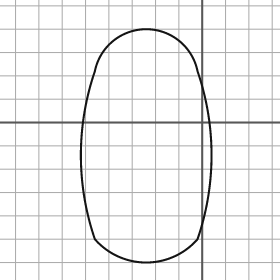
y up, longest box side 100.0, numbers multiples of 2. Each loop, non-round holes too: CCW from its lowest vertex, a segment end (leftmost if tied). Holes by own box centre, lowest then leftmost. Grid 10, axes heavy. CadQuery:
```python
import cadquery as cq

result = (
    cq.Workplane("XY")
    .moveTo(-46.0, -50.0)
    .threePointArc((-24.0, -60.0), (-2.0, -50.0))
    .threePointArc((4.0, -14.0), (-2.0, 22.0))
    .threePointArc((-24.0, 40.0), (-46.0, 22.0))
    .threePointArc((-52.0, -14.0), (-46.0, -50.0))
    .close()
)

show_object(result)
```